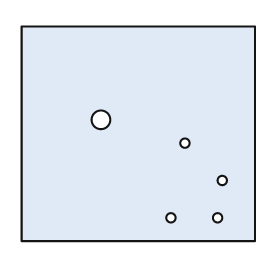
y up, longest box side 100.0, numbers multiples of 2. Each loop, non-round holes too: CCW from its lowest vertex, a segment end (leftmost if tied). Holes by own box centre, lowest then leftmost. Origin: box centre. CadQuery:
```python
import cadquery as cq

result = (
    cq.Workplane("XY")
    .moveTo(-50.0, -46.0)
    .lineTo(50.0, -46.0)
    .lineTo(50.0, 46.0)
    .lineTo(-50.0, 46.0)
    .close()
    .moveTo(14.0, -36.0)
    .circle(2.0)
    .moveTo(34.0, -36.0)
    .circle(2.0)
    .moveTo(36.0, -20.0)
    .circle(2.0)
    .moveTo(20.0, -4.0)
    .circle(2.0)
    .moveTo(-16.0, 6.0)
    .circle(4.0)
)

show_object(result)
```